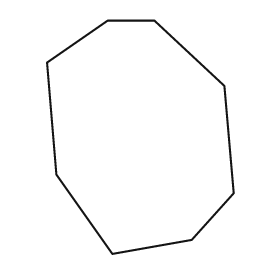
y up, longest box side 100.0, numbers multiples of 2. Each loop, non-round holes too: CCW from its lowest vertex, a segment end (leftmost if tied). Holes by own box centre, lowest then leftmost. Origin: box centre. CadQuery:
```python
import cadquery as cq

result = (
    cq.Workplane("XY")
    .moveTo(-12.0, -50.0)
    .lineTo(22.0, -44.0)
    .lineTo(40.0, -24.0)
    .lineTo(36.0, 22.0)
    .lineTo(6.0, 50.0)
    .lineTo(-14.0, 50.0)
    .lineTo(-40.0, 32.0)
    .lineTo(-36.0, -16.0)
    .close()
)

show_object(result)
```